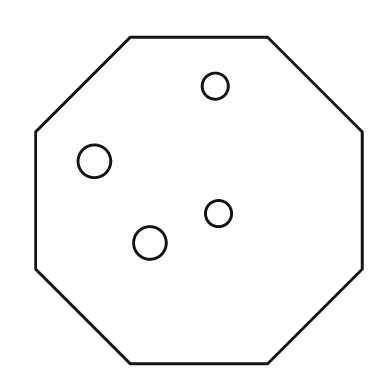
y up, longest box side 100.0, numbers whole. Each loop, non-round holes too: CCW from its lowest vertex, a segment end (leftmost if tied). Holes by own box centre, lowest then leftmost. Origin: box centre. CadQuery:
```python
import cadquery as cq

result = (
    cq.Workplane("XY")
    .moveTo(-21.0, -50.0)
    .lineTo(21.0, -50.0)
    .lineTo(50.0, -21.0)
    .lineTo(50.0, 21.0)
    .lineTo(21.0, 50.0)
    .lineTo(-21.0, 50.0)
    .lineTo(-50.0, 21.0)
    .lineTo(-50.0, -21.0)
    .close()
    .moveTo(-15.0, -13.0)
    .circle(5.0)
    .moveTo(6.0, -4.0)
    .circle(4.0)
    .moveTo(-32.0, 12.0)
    .circle(5.0)
    .moveTo(5.0, 35.0)
    .circle(4.0)
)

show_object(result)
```